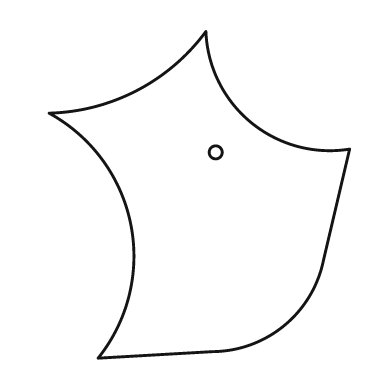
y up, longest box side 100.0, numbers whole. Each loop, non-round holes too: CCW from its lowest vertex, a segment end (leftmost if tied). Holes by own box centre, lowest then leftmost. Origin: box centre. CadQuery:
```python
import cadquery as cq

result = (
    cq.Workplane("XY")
    .moveTo(-31.0, -50.0)
    .lineTo(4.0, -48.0)
    .threePointArc((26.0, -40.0), (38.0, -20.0))
    .lineTo(46.0, 14.0)
    .threePointArc((16.0, 22.0), (2.0, 50.0))
    .threePointArc((-19.0, 32.0), (-46.0, 25.0))
    .threePointArc((-21.0, -9.0), (-31.0, -50.0))
    .close()
    .moveTo(5.0, 13.0)
    .circle(2.0)
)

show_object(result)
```